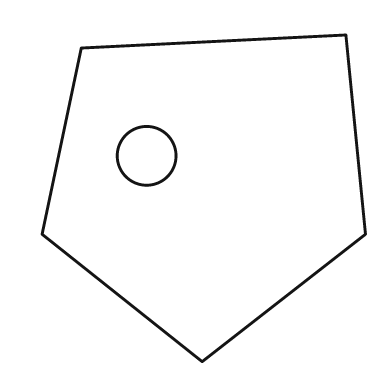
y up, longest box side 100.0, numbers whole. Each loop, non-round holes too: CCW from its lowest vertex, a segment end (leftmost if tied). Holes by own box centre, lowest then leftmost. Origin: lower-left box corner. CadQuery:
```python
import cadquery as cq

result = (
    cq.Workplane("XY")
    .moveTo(49.0, 0.0)
    .lineTo(99.0, 39.0)
    .lineTo(93.0, 100.0)
    .lineTo(12.0, 96.0)
    .lineTo(0.0, 39.0)
    .close()
    .moveTo(32.0, 63.0)
    .circle(9.0)
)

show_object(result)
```